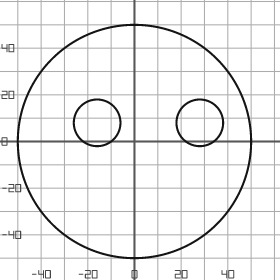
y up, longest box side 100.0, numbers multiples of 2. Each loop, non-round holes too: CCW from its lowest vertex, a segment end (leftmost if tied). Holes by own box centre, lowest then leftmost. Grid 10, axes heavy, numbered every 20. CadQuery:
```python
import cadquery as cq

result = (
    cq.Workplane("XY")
    .moveTo(0.0, 0.0)
    .circle(50.0)
    .moveTo(-16.0, 8.0)
    .circle(10.0)
    .moveTo(28.0, 8.0)
    .circle(10.0)
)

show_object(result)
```